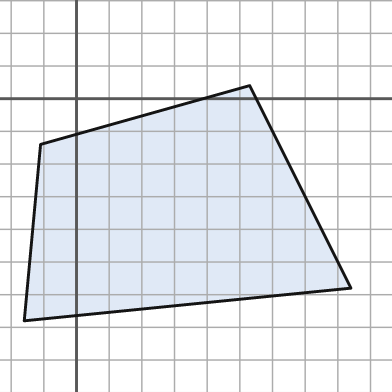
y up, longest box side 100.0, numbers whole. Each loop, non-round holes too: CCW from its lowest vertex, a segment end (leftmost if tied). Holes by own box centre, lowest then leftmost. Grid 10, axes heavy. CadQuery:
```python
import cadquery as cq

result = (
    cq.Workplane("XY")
    .moveTo(-16.0, -68.0)
    .lineTo(84.0, -58.0)
    .lineTo(53.0, 4.0)
    .lineTo(-11.0, -14.0)
    .close()
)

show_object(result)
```